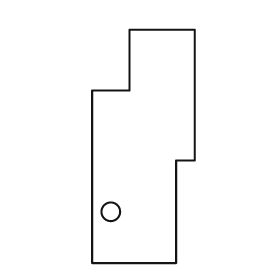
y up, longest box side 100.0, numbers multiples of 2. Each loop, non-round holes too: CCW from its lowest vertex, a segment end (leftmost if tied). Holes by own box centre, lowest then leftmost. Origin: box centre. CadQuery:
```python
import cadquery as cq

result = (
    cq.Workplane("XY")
    .moveTo(-22.0, -50.0)
    .lineTo(14.0, -50.0)
    .lineTo(14.0, -6.0)
    .lineTo(22.0, -6.0)
    .lineTo(22.0, 50.0)
    .lineTo(-6.0, 50.0)
    .lineTo(-6.0, 24.0)
    .lineTo(-22.0, 24.0)
    .close()
    .moveTo(-14.0, -28.0)
    .circle(4.0)
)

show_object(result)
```